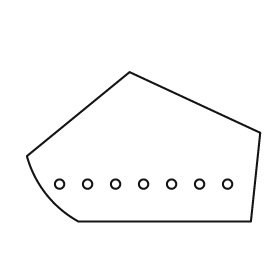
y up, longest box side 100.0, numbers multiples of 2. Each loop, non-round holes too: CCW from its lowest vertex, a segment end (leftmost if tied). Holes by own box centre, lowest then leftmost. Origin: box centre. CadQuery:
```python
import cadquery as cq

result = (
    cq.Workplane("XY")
    .moveTo(-28.0, -32.0)
    .lineTo(46.0, -32.0)
    .lineTo(50.0, 6.0)
    .lineTo(-6.0, 32.0)
    .lineTo(-50.0, -4.0)
    .threePointArc((-42.0, -20.0), (-28.0, -32.0))
    .close()
    .moveTo(-36.0, -16.0)
    .circle(2.0)
    .moveTo(-24.0, -16.0)
    .circle(2.0)
    .moveTo(-12.0, -16.0)
    .circle(2.0)
    .moveTo(0.0, -16.0)
    .circle(2.0)
    .moveTo(12.0, -16.0)
    .circle(2.0)
    .moveTo(24.0, -16.0)
    .circle(2.0)
    .moveTo(36.0, -16.0)
    .circle(2.0)
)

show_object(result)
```